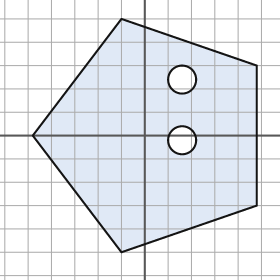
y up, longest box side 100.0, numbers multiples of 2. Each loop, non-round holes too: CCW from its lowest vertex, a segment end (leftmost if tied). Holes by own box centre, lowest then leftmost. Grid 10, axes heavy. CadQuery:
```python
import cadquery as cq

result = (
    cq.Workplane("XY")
    .moveTo(-10.0, -50.0)
    .lineTo(48.0, -30.0)
    .lineTo(48.0, 30.0)
    .lineTo(-10.0, 50.0)
    .lineTo(-48.0, 0.0)
    .close()
    .moveTo(16.0, -2.0)
    .circle(6.0)
    .moveTo(16.0, 24.0)
    .circle(6.0)
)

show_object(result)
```